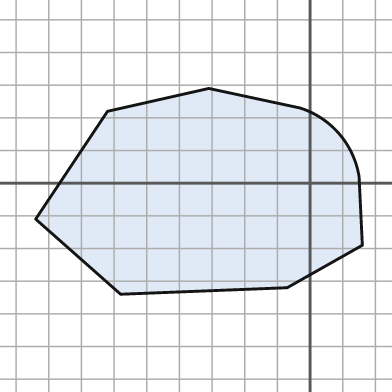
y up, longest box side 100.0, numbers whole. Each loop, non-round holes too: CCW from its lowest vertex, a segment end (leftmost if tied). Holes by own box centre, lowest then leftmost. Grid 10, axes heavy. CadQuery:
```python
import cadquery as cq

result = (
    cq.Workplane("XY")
    .moveTo(-58.0, -34.0)
    .lineTo(-7.0, -32.0)
    .lineTo(16.0, -19.0)
    .lineTo(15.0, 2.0)
    .threePointArc((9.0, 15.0), (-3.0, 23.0))
    .lineTo(-31.0, 29.0)
    .lineTo(-62.0, 22.0)
    .lineTo(-84.0, -11.0)
    .close()
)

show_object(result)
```